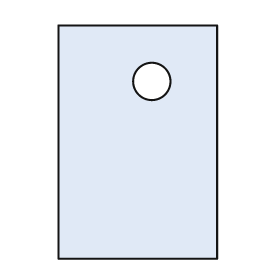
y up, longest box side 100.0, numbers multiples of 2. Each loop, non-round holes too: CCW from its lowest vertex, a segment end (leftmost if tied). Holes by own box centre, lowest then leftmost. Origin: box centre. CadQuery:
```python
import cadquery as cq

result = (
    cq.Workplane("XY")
    .moveTo(-34.0, -50.0)
    .lineTo(34.0, -50.0)
    .lineTo(34.0, 50.0)
    .lineTo(-34.0, 50.0)
    .close()
    .moveTo(6.0, 26.0)
    .circle(8.0)
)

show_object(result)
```